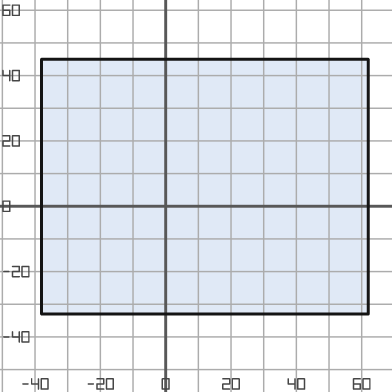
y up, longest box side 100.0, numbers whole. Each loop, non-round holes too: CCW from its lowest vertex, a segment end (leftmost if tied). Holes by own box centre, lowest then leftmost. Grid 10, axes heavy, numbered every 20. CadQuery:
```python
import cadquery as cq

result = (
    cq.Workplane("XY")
    .moveTo(-38.0, -33.0)
    .lineTo(62.0, -33.0)
    .lineTo(62.0, 45.0)
    .lineTo(-38.0, 45.0)
    .close()
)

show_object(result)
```